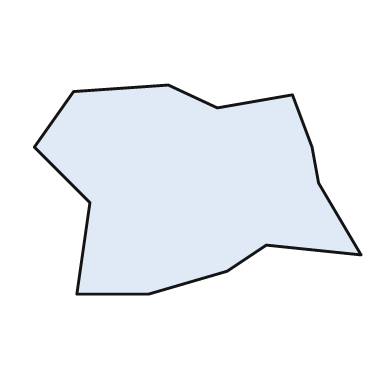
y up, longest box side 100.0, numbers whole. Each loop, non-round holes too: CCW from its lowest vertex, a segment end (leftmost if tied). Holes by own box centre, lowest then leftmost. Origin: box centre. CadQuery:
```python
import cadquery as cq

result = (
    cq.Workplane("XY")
    .moveTo(-37.0, -32.0)
    .lineTo(-15.0, -32.0)
    .lineTo(9.0, -25.0)
    .lineTo(21.0, -17.0)
    .lineTo(50.0, -20.0)
    .lineTo(37.0, 2.0)
    .lineTo(35.0, 13.0)
    .lineTo(29.0, 29.0)
    .lineTo(6.0, 25.0)
    .lineTo(-9.0, 32.0)
    .lineTo(-38.0, 30.0)
    .lineTo(-50.0, 13.0)
    .lineTo(-33.0, -4.0)
    .close()
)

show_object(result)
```